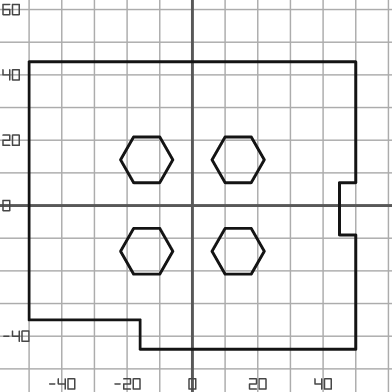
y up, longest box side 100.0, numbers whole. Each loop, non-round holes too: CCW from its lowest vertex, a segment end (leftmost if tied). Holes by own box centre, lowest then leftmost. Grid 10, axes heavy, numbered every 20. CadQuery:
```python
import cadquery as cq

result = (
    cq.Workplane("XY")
    .moveTo(-16.0, -44.0)
    .lineTo(50.0, -44.0)
    .lineTo(50.0, -9.0)
    .lineTo(45.0, -9.0)
    .lineTo(45.0, 7.0)
    .lineTo(50.0, 7.0)
    .lineTo(50.0, 44.0)
    .lineTo(-50.0, 44.0)
    .lineTo(-50.0, -35.0)
    .lineTo(-16.0, -35.0)
    .close()
    .moveTo(-18.0, -21.0)
    .lineTo(-10.0, -21.0)
    .lineTo(-6.0, -14.0)
    .lineTo(-10.0, -7.0)
    .lineTo(-18.0, -7.0)
    .lineTo(-22.0, -14.0)
    .close()
    .moveTo(10.0, -21.0)
    .lineTo(18.0, -21.0)
    .lineTo(22.0, -14.0)
    .lineTo(18.0, -7.0)
    .lineTo(10.0, -7.0)
    .lineTo(6.0, -14.0)
    .close()
    .moveTo(-18.0, 7.0)
    .lineTo(-10.0, 7.0)
    .lineTo(-6.0, 14.0)
    .lineTo(-10.0, 21.0)
    .lineTo(-18.0, 21.0)
    .lineTo(-22.0, 14.0)
    .close()
    .moveTo(10.0, 7.0)
    .lineTo(18.0, 7.0)
    .lineTo(22.0, 14.0)
    .lineTo(18.0, 21.0)
    .lineTo(10.0, 21.0)
    .lineTo(6.0, 14.0)
    .close()
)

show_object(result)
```